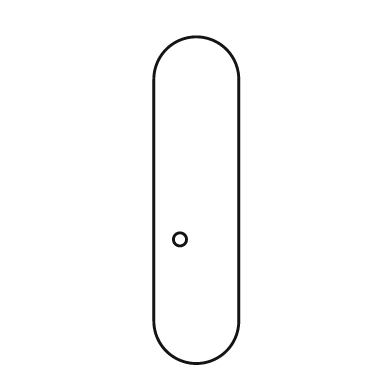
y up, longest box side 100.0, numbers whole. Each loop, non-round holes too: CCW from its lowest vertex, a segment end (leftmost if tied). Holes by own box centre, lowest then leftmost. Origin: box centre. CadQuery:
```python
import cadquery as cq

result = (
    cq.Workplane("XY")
    .moveTo(-13.0, -37.0)
    .threePointArc((0.0, -50.0), (13.0, -37.0))
    .lineTo(13.0, 37.0)
    .threePointArc((0.0, 50.0), (-13.0, 37.0))
    .close()
    .moveTo(-5.0, -12.0)
    .circle(2.0)
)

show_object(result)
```